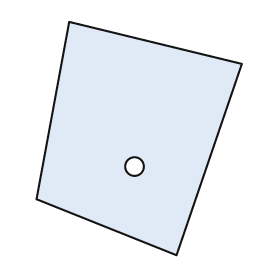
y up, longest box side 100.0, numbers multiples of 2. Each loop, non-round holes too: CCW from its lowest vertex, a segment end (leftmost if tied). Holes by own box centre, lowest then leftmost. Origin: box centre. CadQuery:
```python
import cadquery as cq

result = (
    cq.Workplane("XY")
    .moveTo(16.0, -50.0)
    .lineTo(44.0, 32.0)
    .lineTo(-30.0, 50.0)
    .lineTo(-44.0, -26.0)
    .close()
    .moveTo(-2.0, -12.0)
    .circle(4.0)
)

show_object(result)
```